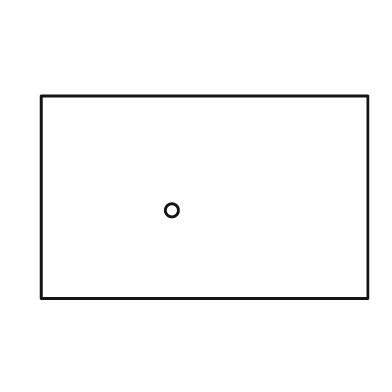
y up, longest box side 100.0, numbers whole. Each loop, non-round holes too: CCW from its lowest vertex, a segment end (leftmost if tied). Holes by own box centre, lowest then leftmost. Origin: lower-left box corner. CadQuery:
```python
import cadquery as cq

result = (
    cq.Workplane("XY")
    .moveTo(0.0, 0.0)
    .lineTo(100.0, 0.0)
    .lineTo(100.0, 62.0)
    .lineTo(0.0, 62.0)
    .close()
    .moveTo(40.0, 27.0)
    .circle(2.0)
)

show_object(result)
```